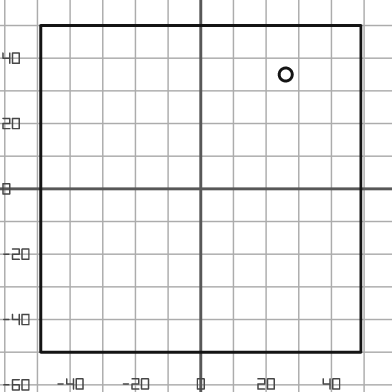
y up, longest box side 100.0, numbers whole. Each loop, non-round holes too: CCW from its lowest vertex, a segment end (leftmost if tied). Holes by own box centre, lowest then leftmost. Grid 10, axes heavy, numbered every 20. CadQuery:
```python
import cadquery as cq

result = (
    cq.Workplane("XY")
    .moveTo(-49.0, -50.0)
    .lineTo(49.0, -50.0)
    .lineTo(49.0, 50.0)
    .lineTo(-49.0, 50.0)
    .close()
    .moveTo(26.0, 35.0)
    .circle(2.0)
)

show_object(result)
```